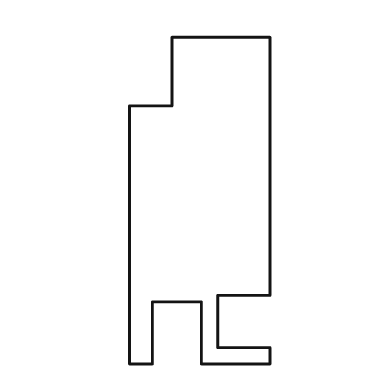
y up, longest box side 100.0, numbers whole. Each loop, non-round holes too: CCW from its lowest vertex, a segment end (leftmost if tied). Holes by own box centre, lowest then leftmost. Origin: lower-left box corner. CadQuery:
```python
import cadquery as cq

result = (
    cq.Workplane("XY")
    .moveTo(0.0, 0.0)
    .lineTo(7.0, 0.0)
    .lineTo(7.0, 19.0)
    .lineTo(22.0, 19.0)
    .lineTo(22.0, 0.0)
    .lineTo(43.0, 0.0)
    .lineTo(43.0, 5.0)
    .lineTo(27.0, 5.0)
    .lineTo(27.0, 21.0)
    .lineTo(43.0, 21.0)
    .lineTo(43.0, 100.0)
    .lineTo(13.0, 100.0)
    .lineTo(13.0, 79.0)
    .lineTo(0.0, 79.0)
    .close()
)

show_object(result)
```